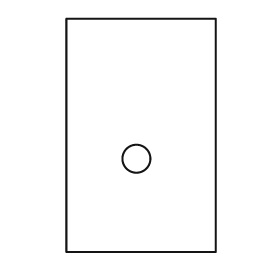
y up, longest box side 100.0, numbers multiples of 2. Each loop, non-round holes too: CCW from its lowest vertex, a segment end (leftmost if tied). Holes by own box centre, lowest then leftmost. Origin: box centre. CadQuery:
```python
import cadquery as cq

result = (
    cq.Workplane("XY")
    .moveTo(-32.0, -50.0)
    .lineTo(32.0, -50.0)
    .lineTo(32.0, 50.0)
    .lineTo(-32.0, 50.0)
    .close()
    .moveTo(-2.0, -10.0)
    .circle(6.0)
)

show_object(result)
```